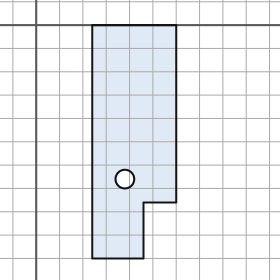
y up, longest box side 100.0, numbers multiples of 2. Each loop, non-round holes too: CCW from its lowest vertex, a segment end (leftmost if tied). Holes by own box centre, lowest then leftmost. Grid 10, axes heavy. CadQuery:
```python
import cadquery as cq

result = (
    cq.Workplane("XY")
    .moveTo(24.0, -100.0)
    .lineTo(46.0, -100.0)
    .lineTo(46.0, -76.0)
    .lineTo(60.0, -76.0)
    .lineTo(60.0, 0.0)
    .lineTo(24.0, 0.0)
    .close()
    .moveTo(38.0, -66.0)
    .circle(4.0)
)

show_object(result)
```